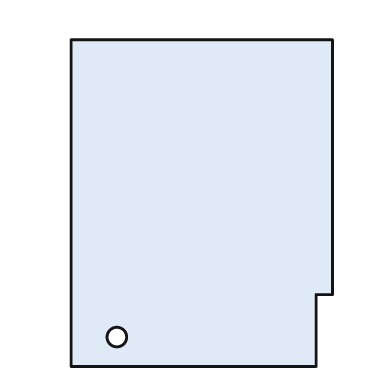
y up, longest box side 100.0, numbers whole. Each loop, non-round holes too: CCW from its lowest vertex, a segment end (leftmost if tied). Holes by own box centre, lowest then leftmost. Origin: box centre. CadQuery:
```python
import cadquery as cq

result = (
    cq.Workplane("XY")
    .moveTo(-40.0, -50.0)
    .lineTo(35.0, -50.0)
    .lineTo(35.0, -28.0)
    .lineTo(40.0, -28.0)
    .lineTo(40.0, 50.0)
    .lineTo(-40.0, 50.0)
    .close()
    .moveTo(-26.0, -41.0)
    .circle(3.0)
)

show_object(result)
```